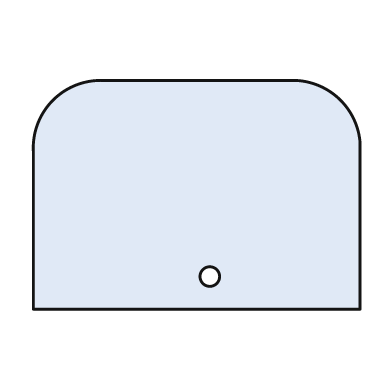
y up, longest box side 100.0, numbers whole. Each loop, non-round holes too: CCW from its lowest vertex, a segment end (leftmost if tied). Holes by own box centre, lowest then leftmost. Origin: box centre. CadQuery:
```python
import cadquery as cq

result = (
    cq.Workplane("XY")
    .moveTo(-50.0, -35.0)
    .lineTo(50.0, -35.0)
    .lineTo(50.0, 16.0)
    .threePointArc((44.0, 29.0), (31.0, 35.0))
    .lineTo(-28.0, 35.0)
    .threePointArc((-44.0, 29.0), (-50.0, 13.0))
    .close()
    .moveTo(4.0, -25.0)
    .circle(3.0)
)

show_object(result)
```